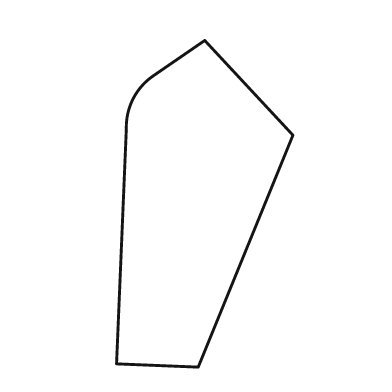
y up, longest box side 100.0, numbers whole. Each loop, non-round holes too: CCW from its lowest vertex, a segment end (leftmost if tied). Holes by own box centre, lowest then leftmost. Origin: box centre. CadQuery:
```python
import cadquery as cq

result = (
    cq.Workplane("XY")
    .moveTo(-2.0, -50.0)
    .lineTo(27.0, 21.0)
    .lineTo(0.0, 50.0)
    .lineTo(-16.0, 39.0)
    .threePointArc((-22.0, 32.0), (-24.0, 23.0))
    .lineTo(-27.0, -49.0)
    .close()
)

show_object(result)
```